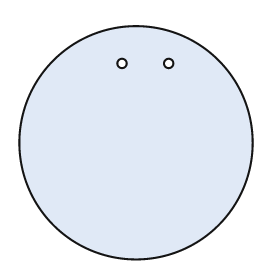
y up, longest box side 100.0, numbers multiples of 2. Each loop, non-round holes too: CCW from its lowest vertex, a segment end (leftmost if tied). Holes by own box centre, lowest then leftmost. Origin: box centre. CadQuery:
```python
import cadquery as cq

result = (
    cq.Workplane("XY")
    .moveTo(0.0, 0.0)
    .circle(50.0)
    .moveTo(-6.0, 34.0)
    .circle(2.0)
    .moveTo(14.0, 34.0)
    .circle(2.0)
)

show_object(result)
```